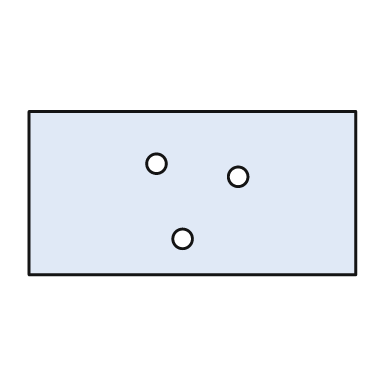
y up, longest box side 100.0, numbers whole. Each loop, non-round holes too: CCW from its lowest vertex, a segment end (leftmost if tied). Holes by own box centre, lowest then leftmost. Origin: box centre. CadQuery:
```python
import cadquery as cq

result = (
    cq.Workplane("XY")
    .moveTo(-50.0, -25.0)
    .lineTo(50.0, -25.0)
    .lineTo(50.0, 25.0)
    .lineTo(-50.0, 25.0)
    .close()
    .moveTo(-3.0, -14.0)
    .circle(3.0)
    .moveTo(14.0, 5.0)
    .circle(3.0)
    .moveTo(-11.0, 9.0)
    .circle(3.0)
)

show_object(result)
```